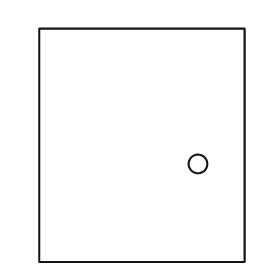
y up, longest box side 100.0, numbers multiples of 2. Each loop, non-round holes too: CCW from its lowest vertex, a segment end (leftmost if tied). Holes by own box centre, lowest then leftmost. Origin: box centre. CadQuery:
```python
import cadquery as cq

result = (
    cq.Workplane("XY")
    .moveTo(-44.0, -50.0)
    .lineTo(44.0, -50.0)
    .lineTo(44.0, 50.0)
    .lineTo(-44.0, 50.0)
    .close()
    .moveTo(24.0, -8.0)
    .circle(4.0)
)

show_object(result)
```